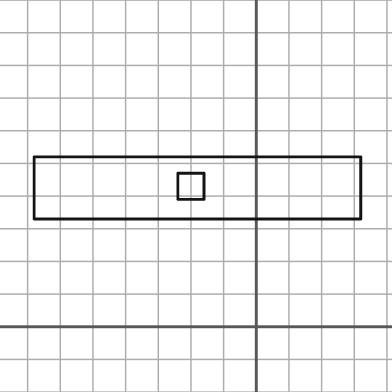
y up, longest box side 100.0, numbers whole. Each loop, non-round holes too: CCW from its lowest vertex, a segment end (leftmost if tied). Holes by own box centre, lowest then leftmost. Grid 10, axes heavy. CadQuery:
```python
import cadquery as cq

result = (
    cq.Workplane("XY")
    .moveTo(-68.0, 33.0)
    .lineTo(32.0, 33.0)
    .lineTo(32.0, 52.0)
    .lineTo(-68.0, 52.0)
    .close()
    .moveTo(-24.0, 39.0)
    .lineTo(-16.0, 39.0)
    .lineTo(-16.0, 47.0)
    .lineTo(-24.0, 47.0)
    .close()
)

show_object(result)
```